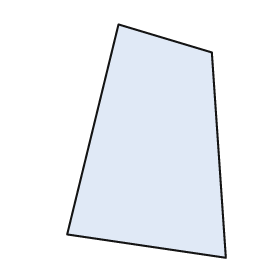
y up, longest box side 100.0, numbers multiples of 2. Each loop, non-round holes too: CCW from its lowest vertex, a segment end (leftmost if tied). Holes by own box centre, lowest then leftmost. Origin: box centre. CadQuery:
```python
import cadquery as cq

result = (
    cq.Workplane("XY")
    .moveTo(34.0, -50.0)
    .lineTo(28.0, 38.0)
    .lineTo(-12.0, 50.0)
    .lineTo(-34.0, -40.0)
    .close()
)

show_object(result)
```